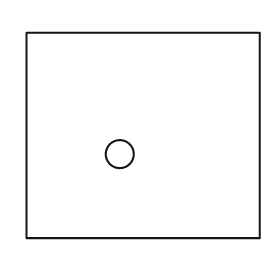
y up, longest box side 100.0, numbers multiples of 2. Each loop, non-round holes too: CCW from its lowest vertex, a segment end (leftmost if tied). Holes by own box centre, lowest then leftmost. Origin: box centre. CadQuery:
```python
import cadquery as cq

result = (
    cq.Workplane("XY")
    .moveTo(-50.0, -44.0)
    .lineTo(50.0, -44.0)
    .lineTo(50.0, 44.0)
    .lineTo(-50.0, 44.0)
    .close()
    .moveTo(-10.0, -8.0)
    .circle(6.0)
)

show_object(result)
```